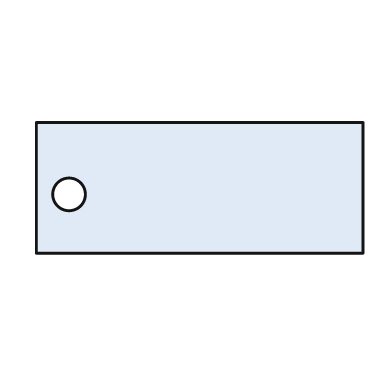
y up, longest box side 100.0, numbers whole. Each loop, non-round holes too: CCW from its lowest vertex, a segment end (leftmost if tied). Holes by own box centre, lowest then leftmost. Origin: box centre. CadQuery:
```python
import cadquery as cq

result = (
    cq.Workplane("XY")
    .moveTo(-50.0, -20.0)
    .lineTo(50.0, -20.0)
    .lineTo(50.0, 20.0)
    .lineTo(-50.0, 20.0)
    .close()
    .moveTo(-40.0, -2.0)
    .circle(5.0)
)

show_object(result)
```